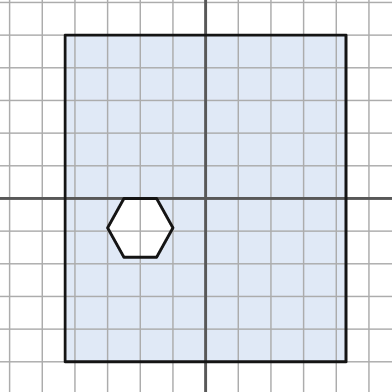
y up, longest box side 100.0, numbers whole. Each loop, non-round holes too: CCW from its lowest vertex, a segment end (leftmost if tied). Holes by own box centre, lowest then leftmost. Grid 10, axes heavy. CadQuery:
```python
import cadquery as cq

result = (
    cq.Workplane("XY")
    .moveTo(-43.0, -50.0)
    .lineTo(43.0, -50.0)
    .lineTo(43.0, 50.0)
    .lineTo(-43.0, 50.0)
    .close()
    .moveTo(-25.0, -18.0)
    .lineTo(-15.0, -18.0)
    .lineTo(-10.0, -9.0)
    .lineTo(-15.0, 0.0)
    .lineTo(-25.0, 0.0)
    .lineTo(-30.0, -9.0)
    .close()
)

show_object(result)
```